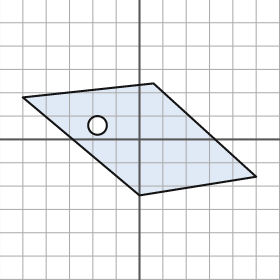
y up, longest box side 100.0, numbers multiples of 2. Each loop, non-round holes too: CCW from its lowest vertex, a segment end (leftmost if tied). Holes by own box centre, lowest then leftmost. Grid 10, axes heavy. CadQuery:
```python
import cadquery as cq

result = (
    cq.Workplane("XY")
    .moveTo(0.0, -24.0)
    .lineTo(50.0, -16.0)
    .lineTo(6.0, 24.0)
    .lineTo(-50.0, 18.0)
    .close()
    .moveTo(-18.0, 6.0)
    .circle(4.0)
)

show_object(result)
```